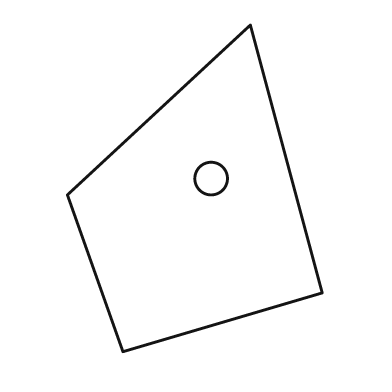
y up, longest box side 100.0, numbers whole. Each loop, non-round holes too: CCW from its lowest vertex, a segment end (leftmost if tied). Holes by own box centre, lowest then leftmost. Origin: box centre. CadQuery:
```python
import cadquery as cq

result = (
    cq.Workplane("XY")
    .moveTo(-22.0, -50.0)
    .lineTo(39.0, -32.0)
    .lineTo(17.0, 50.0)
    .lineTo(-39.0, -2.0)
    .close()
    .moveTo(5.0, 3.0)
    .circle(5.0)
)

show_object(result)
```